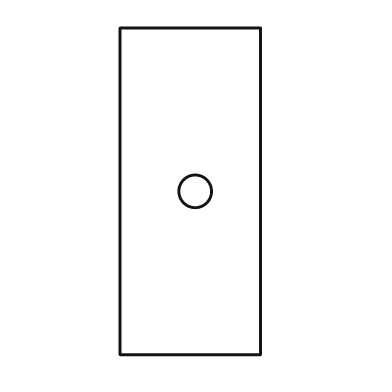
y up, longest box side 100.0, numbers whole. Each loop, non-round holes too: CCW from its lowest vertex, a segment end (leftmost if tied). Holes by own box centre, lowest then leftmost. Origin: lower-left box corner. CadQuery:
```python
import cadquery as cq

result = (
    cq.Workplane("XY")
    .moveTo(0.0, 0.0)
    .lineTo(43.0, 0.0)
    .lineTo(43.0, 100.0)
    .lineTo(0.0, 100.0)
    .close()
    .moveTo(23.0, 50.0)
    .circle(5.0)
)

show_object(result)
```